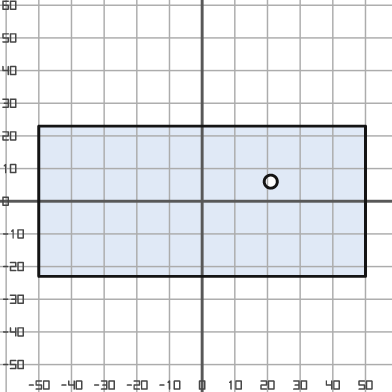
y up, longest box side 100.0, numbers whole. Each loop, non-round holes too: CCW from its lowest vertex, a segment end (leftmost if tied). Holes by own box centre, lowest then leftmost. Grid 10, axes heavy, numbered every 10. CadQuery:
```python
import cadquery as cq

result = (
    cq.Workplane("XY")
    .moveTo(-50.0, -23.0)
    .lineTo(50.0, -23.0)
    .lineTo(50.0, 23.0)
    .lineTo(-50.0, 23.0)
    .close()
    .moveTo(21.0, 6.0)
    .circle(2.0)
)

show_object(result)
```